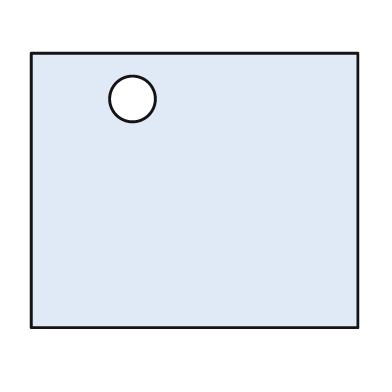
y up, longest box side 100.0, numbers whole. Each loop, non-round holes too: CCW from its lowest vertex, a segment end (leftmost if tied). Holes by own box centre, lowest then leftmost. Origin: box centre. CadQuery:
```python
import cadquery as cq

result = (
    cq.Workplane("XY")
    .moveTo(-50.0, -42.0)
    .lineTo(50.0, -42.0)
    .lineTo(50.0, 42.0)
    .lineTo(-50.0, 42.0)
    .close()
    .moveTo(-19.0, 28.0)
    .circle(7.0)
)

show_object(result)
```